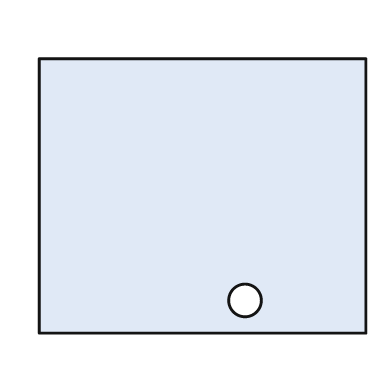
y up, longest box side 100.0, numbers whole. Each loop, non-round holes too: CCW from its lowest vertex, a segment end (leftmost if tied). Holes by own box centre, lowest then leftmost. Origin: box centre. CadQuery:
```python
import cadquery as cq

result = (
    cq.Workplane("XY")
    .moveTo(-50.0, -42.0)
    .lineTo(50.0, -42.0)
    .lineTo(50.0, 42.0)
    .lineTo(-50.0, 42.0)
    .close()
    .moveTo(13.0, -32.0)
    .circle(5.0)
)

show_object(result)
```